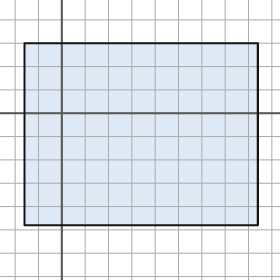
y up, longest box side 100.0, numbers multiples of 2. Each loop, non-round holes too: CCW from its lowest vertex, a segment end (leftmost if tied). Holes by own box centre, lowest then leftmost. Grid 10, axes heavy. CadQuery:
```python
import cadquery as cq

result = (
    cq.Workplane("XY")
    .moveTo(-16.0, -48.0)
    .lineTo(84.0, -48.0)
    .lineTo(84.0, 30.0)
    .lineTo(-16.0, 30.0)
    .close()
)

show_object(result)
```